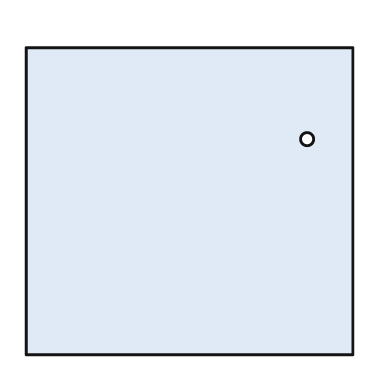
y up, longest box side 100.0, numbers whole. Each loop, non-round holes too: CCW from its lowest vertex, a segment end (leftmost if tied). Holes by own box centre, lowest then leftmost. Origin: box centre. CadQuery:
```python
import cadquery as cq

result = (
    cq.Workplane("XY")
    .moveTo(-50.0, -47.0)
    .lineTo(50.0, -47.0)
    .lineTo(50.0, 47.0)
    .lineTo(-50.0, 47.0)
    .close()
    .moveTo(36.0, 19.0)
    .circle(2.0)
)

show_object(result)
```